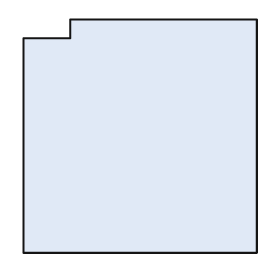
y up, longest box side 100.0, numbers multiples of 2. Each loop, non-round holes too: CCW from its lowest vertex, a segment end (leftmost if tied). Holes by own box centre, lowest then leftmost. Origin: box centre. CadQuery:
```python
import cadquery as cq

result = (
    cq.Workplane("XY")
    .moveTo(-50.0, -50.0)
    .lineTo(50.0, -50.0)
    .lineTo(50.0, 50.0)
    .lineTo(-30.0, 50.0)
    .lineTo(-30.0, 42.0)
    .lineTo(-50.0, 42.0)
    .close()
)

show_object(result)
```